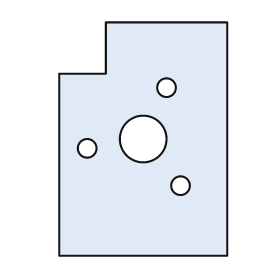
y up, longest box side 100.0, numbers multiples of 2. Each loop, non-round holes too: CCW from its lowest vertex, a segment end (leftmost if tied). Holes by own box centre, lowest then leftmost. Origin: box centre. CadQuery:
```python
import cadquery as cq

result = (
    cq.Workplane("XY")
    .moveTo(-36.0, -50.0)
    .lineTo(36.0, -50.0)
    .lineTo(36.0, 50.0)
    .lineTo(-16.0, 50.0)
    .lineTo(-16.0, 28.0)
    .lineTo(-36.0, 28.0)
    .close()
    .moveTo(16.0, -20.0)
    .circle(4.0)
    .moveTo(-24.0, -4.0)
    .circle(4.0)
    .moveTo(0.0, 0.0)
    .circle(10.0)
    .moveTo(10.0, 22.0)
    .circle(4.0)
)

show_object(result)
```